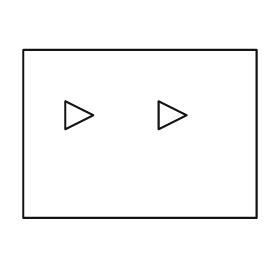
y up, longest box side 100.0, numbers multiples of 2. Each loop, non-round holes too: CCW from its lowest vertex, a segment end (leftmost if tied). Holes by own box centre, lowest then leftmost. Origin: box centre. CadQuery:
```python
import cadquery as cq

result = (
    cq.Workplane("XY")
    .moveTo(-50.0, -36.0)
    .lineTo(50.0, -36.0)
    .lineTo(50.0, 36.0)
    .lineTo(-50.0, 36.0)
    .close()
    .moveTo(-32.0, 2.0)
    .lineTo(-20.0, 8.0)
    .lineTo(-32.0, 14.0)
    .close()
    .moveTo(8.0, 2.0)
    .lineTo(20.0, 8.0)
    .lineTo(8.0, 14.0)
    .close()
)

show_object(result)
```